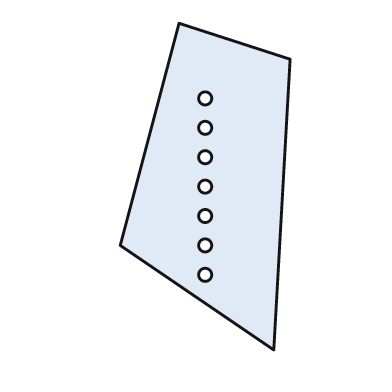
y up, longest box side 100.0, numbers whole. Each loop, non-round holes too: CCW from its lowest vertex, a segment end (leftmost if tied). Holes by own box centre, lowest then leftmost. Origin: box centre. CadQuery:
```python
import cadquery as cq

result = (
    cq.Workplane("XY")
    .moveTo(21.0, -50.0)
    .lineTo(26.0, 39.0)
    .lineTo(-8.0, 50.0)
    .lineTo(-26.0, -18.0)
    .close()
    .moveTo(0.0, -27.0)
    .circle(2.0)
    .moveTo(0.0, -18.0)
    .circle(2.0)
    .moveTo(0.0, -9.0)
    .circle(2.0)
    .moveTo(0.0, 0.0)
    .circle(2.0)
    .moveTo(0.0, 9.0)
    .circle(2.0)
    .moveTo(0.0, 18.0)
    .circle(2.0)
    .moveTo(0.0, 27.0)
    .circle(2.0)
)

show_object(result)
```